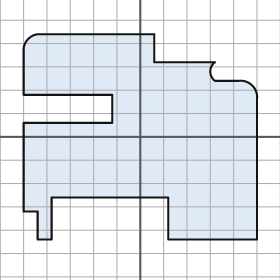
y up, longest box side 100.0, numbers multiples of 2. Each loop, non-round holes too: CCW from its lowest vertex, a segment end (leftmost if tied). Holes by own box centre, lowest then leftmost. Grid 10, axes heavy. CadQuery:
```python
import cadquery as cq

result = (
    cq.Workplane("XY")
    .moveTo(-44.0, -44.0)
    .lineTo(-38.0, -44.0)
    .lineTo(-38.0, -26.0)
    .lineTo(12.0, -26.0)
    .lineTo(12.0, -44.0)
    .lineTo(50.0, -44.0)
    .lineTo(50.0, 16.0)
    .threePointArc((48.0, 22.0), (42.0, 24.0))
    .lineTo(32.0, 24.0)
    .threePointArc((30.0, 28.0), (32.0, 32.0))
    .lineTo(6.0, 32.0)
    .lineTo(6.0, 44.0)
    .lineTo(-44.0, 44.0)
    .threePointArc((-48.0, 42.0), (-50.0, 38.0))
    .lineTo(-50.0, 18.0)
    .lineTo(-12.0, 18.0)
    .lineTo(-12.0, 6.0)
    .lineTo(-50.0, 6.0)
    .lineTo(-50.0, -32.0)
    .lineTo(-44.0, -32.0)
    .close()
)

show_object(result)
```